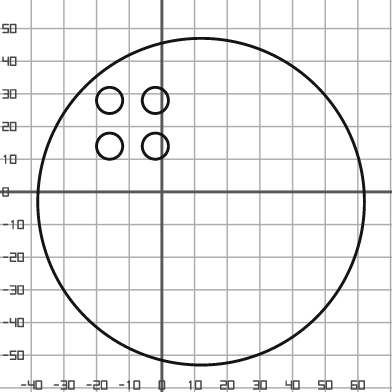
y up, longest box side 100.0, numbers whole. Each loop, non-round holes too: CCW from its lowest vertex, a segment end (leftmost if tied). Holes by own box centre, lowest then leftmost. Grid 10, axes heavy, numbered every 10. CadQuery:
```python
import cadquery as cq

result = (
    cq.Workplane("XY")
    .moveTo(12.0, -3.0)
    .circle(50.0)
    .moveTo(-16.0, 14.0)
    .circle(4.0)
    .moveTo(-2.0, 14.0)
    .circle(4.0)
    .moveTo(-16.0, 28.0)
    .circle(4.0)
    .moveTo(-2.0, 28.0)
    .circle(4.0)
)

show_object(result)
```